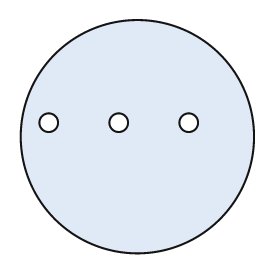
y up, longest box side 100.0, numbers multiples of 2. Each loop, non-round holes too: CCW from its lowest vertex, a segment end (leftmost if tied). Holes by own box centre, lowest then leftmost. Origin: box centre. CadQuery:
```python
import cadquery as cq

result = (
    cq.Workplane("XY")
    .moveTo(0.0, 0.0)
    .circle(50.0)
    .moveTo(-38.0, 6.0)
    .circle(4.0)
    .moveTo(-8.0, 6.0)
    .circle(4.0)
    .moveTo(22.0, 6.0)
    .circle(4.0)
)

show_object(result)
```